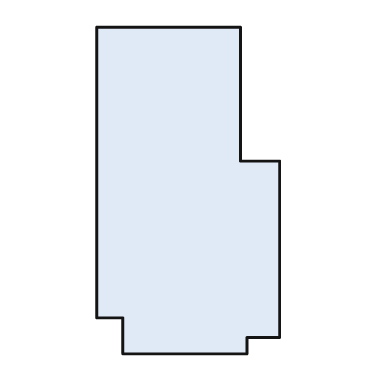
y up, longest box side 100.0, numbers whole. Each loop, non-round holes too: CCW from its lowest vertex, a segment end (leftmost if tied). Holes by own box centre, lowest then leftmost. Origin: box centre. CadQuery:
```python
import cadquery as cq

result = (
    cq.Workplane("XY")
    .moveTo(-20.0, -50.0)
    .lineTo(18.0, -50.0)
    .lineTo(18.0, -45.0)
    .lineTo(28.0, -45.0)
    .lineTo(28.0, 9.0)
    .lineTo(16.0, 9.0)
    .lineTo(16.0, 50.0)
    .lineTo(-28.0, 50.0)
    .lineTo(-28.0, -39.0)
    .lineTo(-20.0, -39.0)
    .close()
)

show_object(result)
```